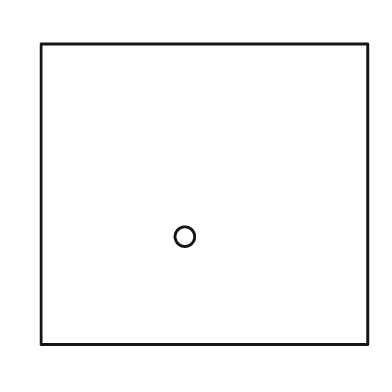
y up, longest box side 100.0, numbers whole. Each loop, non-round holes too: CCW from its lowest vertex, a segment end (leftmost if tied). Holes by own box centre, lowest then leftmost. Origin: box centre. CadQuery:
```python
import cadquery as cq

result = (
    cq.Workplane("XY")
    .moveTo(-50.0, -46.0)
    .lineTo(50.0, -46.0)
    .lineTo(50.0, 46.0)
    .lineTo(-50.0, 46.0)
    .close()
    .moveTo(-6.0, -13.0)
    .circle(3.0)
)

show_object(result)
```